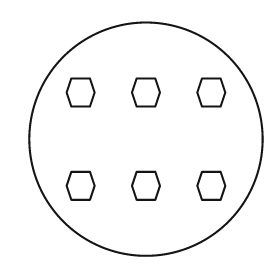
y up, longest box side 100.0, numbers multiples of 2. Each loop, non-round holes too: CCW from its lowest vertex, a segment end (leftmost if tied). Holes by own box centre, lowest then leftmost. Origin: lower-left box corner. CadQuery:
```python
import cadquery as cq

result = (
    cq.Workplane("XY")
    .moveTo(50.0, 50.0)
    .circle(50.0)
    .moveTo(18.0, 24.0)
    .lineTo(26.0, 24.0)
    .lineTo(28.0, 30.0)
    .lineTo(26.0, 36.0)
    .lineTo(18.0, 36.0)
    .lineTo(16.0, 30.0)
    .close()
    .moveTo(46.0, 24.0)
    .lineTo(54.0, 24.0)
    .lineTo(56.0, 30.0)
    .lineTo(54.0, 36.0)
    .lineTo(46.0, 36.0)
    .lineTo(44.0, 30.0)
    .close()
    .moveTo(74.0, 24.0)
    .lineTo(82.0, 24.0)
    .lineTo(84.0, 30.0)
    .lineTo(82.0, 36.0)
    .lineTo(74.0, 36.0)
    .lineTo(72.0, 30.0)
    .close()
    .moveTo(18.0, 64.0)
    .lineTo(26.0, 64.0)
    .lineTo(28.0, 70.0)
    .lineTo(26.0, 76.0)
    .lineTo(18.0, 76.0)
    .lineTo(16.0, 70.0)
    .close()
    .moveTo(46.0, 64.0)
    .lineTo(54.0, 64.0)
    .lineTo(56.0, 70.0)
    .lineTo(54.0, 76.0)
    .lineTo(46.0, 76.0)
    .lineTo(44.0, 70.0)
    .close()
    .moveTo(74.0, 64.0)
    .lineTo(82.0, 64.0)
    .lineTo(84.0, 70.0)
    .lineTo(82.0, 76.0)
    .lineTo(74.0, 76.0)
    .lineTo(72.0, 70.0)
    .close()
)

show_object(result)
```